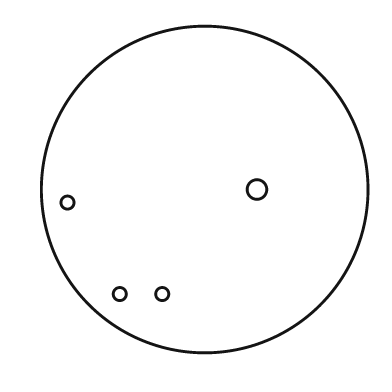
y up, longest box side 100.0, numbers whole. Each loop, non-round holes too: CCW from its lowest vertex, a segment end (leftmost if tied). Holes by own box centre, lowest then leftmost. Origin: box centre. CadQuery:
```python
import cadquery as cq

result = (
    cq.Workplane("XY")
    .moveTo(0.0, 0.0)
    .circle(50.0)
    .moveTo(-26.0, -32.0)
    .circle(2.0)
    .moveTo(-13.0, -32.0)
    .circle(2.0)
    .moveTo(-42.0, -4.0)
    .circle(2.0)
    .moveTo(16.0, 0.0)
    .circle(3.0)
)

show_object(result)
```